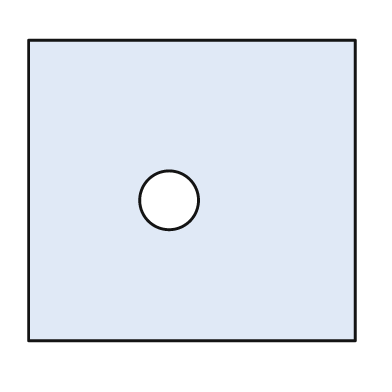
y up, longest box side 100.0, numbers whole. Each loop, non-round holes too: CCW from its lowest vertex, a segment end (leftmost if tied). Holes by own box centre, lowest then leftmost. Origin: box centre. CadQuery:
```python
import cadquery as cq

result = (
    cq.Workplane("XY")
    .moveTo(-50.0, -46.0)
    .lineTo(50.0, -46.0)
    .lineTo(50.0, 46.0)
    .lineTo(-50.0, 46.0)
    .close()
    .moveTo(-7.0, -3.0)
    .circle(9.0)
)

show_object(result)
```